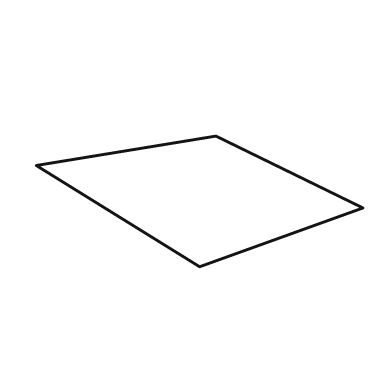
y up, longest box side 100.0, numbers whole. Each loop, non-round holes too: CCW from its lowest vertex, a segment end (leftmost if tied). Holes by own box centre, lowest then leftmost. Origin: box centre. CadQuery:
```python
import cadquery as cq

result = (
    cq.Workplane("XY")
    .moveTo(0.0, -20.0)
    .lineTo(50.0, -2.0)
    .lineTo(5.0, 20.0)
    .lineTo(-50.0, 11.0)
    .close()
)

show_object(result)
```